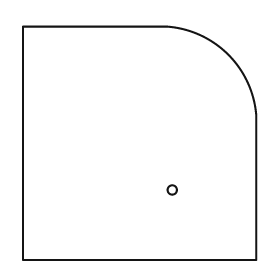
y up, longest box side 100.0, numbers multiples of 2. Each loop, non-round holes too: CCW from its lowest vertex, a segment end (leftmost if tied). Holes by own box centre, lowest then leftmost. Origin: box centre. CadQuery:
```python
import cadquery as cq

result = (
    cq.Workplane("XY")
    .moveTo(-50.0, -50.0)
    .lineTo(50.0, -50.0)
    .lineTo(50.0, 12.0)
    .threePointArc((38.0, 38.0), (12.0, 50.0))
    .lineTo(-50.0, 50.0)
    .close()
    .moveTo(14.0, -20.0)
    .circle(2.0)
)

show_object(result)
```